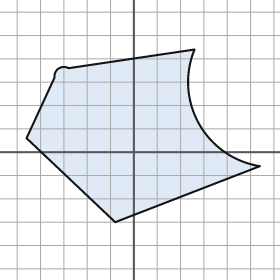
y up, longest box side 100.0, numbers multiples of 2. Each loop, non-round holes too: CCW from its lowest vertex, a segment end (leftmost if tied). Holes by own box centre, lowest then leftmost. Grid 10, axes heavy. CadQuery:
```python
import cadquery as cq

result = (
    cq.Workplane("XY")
    .moveTo(-8.0, -30.0)
    .lineTo(54.0, -6.0)
    .threePointArc((28.0, 12.0), (26.0, 44.0))
    .lineTo(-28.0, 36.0)
    .threePointArc((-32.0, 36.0), (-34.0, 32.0))
    .lineTo(-46.0, 6.0)
    .close()
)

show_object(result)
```